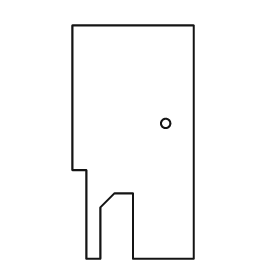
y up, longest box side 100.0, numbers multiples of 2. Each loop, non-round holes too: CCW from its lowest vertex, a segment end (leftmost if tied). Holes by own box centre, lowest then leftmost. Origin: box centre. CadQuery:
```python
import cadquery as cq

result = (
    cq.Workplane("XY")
    .moveTo(-20.0, -50.0)
    .lineTo(-14.0, -50.0)
    .lineTo(-14.0, -28.0)
    .lineTo(-8.0, -22.0)
    .lineTo(0.0, -22.0)
    .lineTo(0.0, -50.0)
    .lineTo(26.0, -50.0)
    .lineTo(26.0, 50.0)
    .lineTo(-26.0, 50.0)
    .lineTo(-26.0, -12.0)
    .lineTo(-20.0, -12.0)
    .close()
    .moveTo(14.0, 8.0)
    .circle(2.0)
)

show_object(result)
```